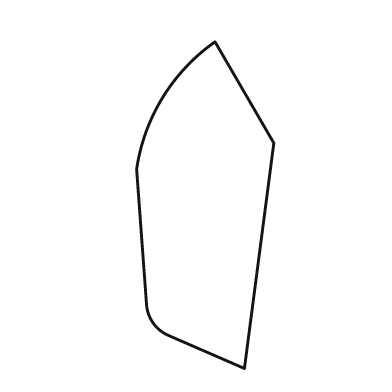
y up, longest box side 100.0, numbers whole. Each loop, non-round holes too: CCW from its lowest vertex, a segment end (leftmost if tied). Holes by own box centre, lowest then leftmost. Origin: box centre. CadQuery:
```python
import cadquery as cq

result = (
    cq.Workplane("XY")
    .moveTo(12.0, -50.0)
    .lineTo(21.0, 19.0)
    .lineTo(3.0, 50.0)
    .threePointArc((-13.0, 33.0), (-21.0, 11.0))
    .lineTo(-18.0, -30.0)
    .threePointArc((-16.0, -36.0), (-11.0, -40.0))
    .close()
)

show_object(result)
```